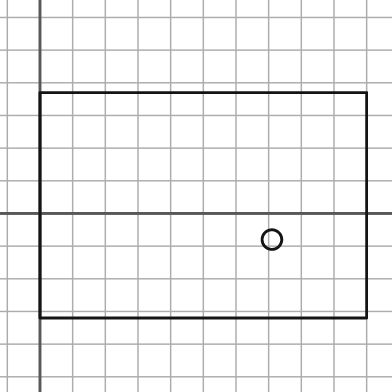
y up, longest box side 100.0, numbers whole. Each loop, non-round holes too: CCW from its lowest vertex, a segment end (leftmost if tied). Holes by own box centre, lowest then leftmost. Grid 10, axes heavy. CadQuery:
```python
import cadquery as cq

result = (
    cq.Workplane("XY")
    .moveTo(0.0, -32.0)
    .lineTo(100.0, -32.0)
    .lineTo(100.0, 37.0)
    .lineTo(0.0, 37.0)
    .close()
    .moveTo(71.0, -8.0)
    .circle(3.0)
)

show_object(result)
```